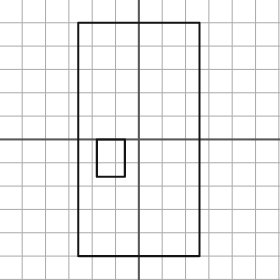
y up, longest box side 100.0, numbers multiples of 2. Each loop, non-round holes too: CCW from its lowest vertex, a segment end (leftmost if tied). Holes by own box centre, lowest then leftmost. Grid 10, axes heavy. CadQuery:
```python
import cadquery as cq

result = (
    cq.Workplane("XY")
    .moveTo(-26.0, -50.0)
    .lineTo(26.0, -50.0)
    .lineTo(26.0, 50.0)
    .lineTo(-26.0, 50.0)
    .close()
    .moveTo(-18.0, -16.0)
    .lineTo(-6.0, -16.0)
    .lineTo(-6.0, 0.0)
    .lineTo(-18.0, 0.0)
    .close()
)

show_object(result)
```